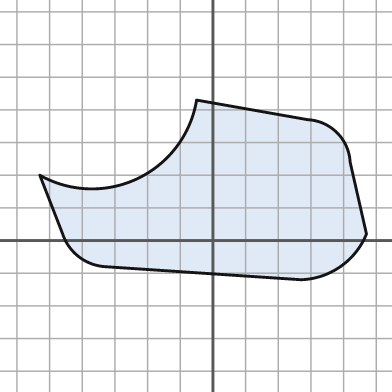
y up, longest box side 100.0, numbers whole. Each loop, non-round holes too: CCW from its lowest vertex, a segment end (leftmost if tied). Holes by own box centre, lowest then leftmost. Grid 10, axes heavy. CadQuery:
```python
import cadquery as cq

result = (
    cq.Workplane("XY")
    .moveTo(27.0, -12.0)
    .threePointArc((39.0, -8.0), (47.0, 2.0))
    .lineTo(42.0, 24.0)
    .threePointArc((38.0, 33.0), (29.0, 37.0))
    .lineTo(-5.0, 43.0)
    .threePointArc((-23.0, 19.0), (-53.0, 20.0))
    .lineTo(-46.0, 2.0)
    .threePointArc((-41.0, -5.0), (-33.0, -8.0))
    .close()
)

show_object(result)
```